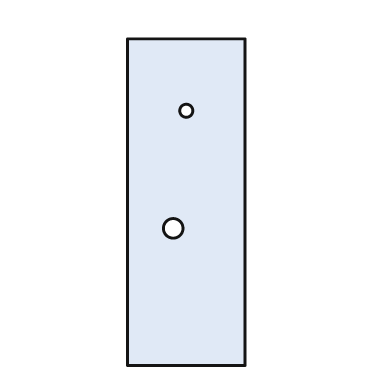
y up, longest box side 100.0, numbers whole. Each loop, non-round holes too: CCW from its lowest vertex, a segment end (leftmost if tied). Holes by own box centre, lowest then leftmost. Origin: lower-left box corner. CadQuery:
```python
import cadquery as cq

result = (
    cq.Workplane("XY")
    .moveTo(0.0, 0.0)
    .lineTo(36.0, 0.0)
    .lineTo(36.0, 100.0)
    .lineTo(0.0, 100.0)
    .close()
    .moveTo(14.0, 42.0)
    .circle(3.0)
    .moveTo(18.0, 78.0)
    .circle(2.0)
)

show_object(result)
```